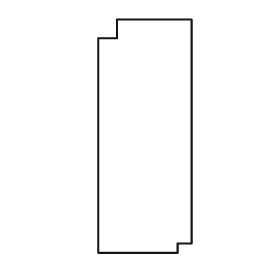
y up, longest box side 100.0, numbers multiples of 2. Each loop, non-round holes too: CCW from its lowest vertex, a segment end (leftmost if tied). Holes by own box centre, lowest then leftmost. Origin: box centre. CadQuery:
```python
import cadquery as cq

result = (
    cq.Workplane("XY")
    .moveTo(-20.0, -50.0)
    .lineTo(14.0, -50.0)
    .lineTo(14.0, -46.0)
    .lineTo(20.0, -46.0)
    .lineTo(20.0, 50.0)
    .lineTo(-12.0, 50.0)
    .lineTo(-12.0, 42.0)
    .lineTo(-20.0, 42.0)
    .close()
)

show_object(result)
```